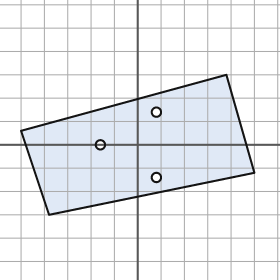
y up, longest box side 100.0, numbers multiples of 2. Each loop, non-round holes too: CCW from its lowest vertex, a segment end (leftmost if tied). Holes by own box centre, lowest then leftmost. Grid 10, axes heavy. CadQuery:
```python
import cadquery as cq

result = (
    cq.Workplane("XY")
    .moveTo(-38.0, -30.0)
    .lineTo(50.0, -12.0)
    .lineTo(38.0, 30.0)
    .lineTo(-50.0, 6.0)
    .close()
    .moveTo(8.0, -14.0)
    .circle(2.0)
    .moveTo(-16.0, 0.0)
    .circle(2.0)
    .moveTo(8.0, 14.0)
    .circle(2.0)
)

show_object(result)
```